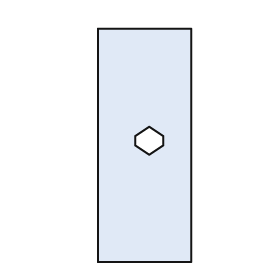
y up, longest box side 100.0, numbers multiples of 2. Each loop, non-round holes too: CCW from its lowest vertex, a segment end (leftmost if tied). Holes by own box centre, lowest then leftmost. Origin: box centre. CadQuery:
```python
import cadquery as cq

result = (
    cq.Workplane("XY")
    .moveTo(-20.0, -50.0)
    .lineTo(20.0, -50.0)
    .lineTo(20.0, 50.0)
    .lineTo(-20.0, 50.0)
    .close()
    .moveTo(2.0, -4.0)
    .lineTo(8.0, 0.0)
    .lineTo(8.0, 4.0)
    .lineTo(2.0, 8.0)
    .lineTo(-4.0, 4.0)
    .lineTo(-4.0, 0.0)
    .close()
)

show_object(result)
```